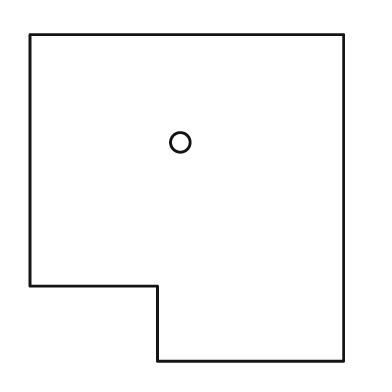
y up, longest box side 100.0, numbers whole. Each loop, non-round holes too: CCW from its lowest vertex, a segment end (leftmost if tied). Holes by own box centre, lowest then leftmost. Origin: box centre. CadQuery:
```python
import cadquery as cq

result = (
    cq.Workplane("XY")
    .moveTo(-9.0, -50.0)
    .lineTo(48.0, -50.0)
    .lineTo(48.0, 50.0)
    .lineTo(-48.0, 50.0)
    .lineTo(-48.0, -27.0)
    .lineTo(-9.0, -27.0)
    .close()
    .moveTo(-2.0, 17.0)
    .circle(3.0)
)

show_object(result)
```